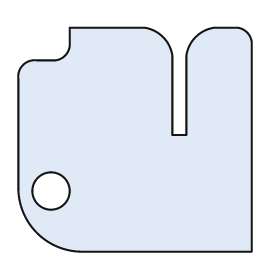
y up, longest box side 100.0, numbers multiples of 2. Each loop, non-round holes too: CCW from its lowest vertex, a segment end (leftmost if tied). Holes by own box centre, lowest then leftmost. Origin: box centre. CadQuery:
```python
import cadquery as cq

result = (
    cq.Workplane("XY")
    .moveTo(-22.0, -48.0)
    .lineTo(50.0, -48.0)
    .lineTo(50.0, 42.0)
    .threePointArc((48.0, 46.0), (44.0, 48.0))
    .lineTo(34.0, 48.0)
    .threePointArc((26.0, 44.0), (22.0, 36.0))
    .lineTo(22.0, 2.0)
    .lineTo(16.0, 2.0)
    .lineTo(16.0, 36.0)
    .threePointArc((12.0, 44.0), (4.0, 48.0))
    .lineTo(-28.0, 48.0)
    .lineTo(-28.0, 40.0)
    .threePointArc((-30.0, 36.0), (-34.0, 34.0))
    .lineTo(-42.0, 34.0)
    .threePointArc((-48.0, 32.0), (-50.0, 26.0))
    .lineTo(-50.0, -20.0)
    .threePointArc((-42.0, -40.0), (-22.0, -48.0))
    .close()
    .moveTo(-36.0, -22.0)
    .circle(8.0)
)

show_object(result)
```